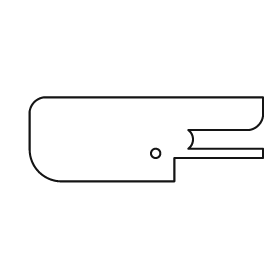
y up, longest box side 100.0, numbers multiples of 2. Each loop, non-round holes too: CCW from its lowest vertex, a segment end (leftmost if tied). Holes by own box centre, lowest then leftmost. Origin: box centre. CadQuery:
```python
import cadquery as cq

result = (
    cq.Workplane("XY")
    .moveTo(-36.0, -18.0)
    .lineTo(12.0, -18.0)
    .lineTo(12.0, -8.0)
    .lineTo(50.0, -8.0)
    .lineTo(50.0, -4.0)
    .lineTo(18.0, -4.0)
    .threePointArc((20.0, 0.0), (18.0, 4.0))
    .lineTo(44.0, 4.0)
    .threePointArc((48.0, 6.0), (50.0, 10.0))
    .lineTo(50.0, 18.0)
    .lineTo(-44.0, 18.0)
    .threePointArc((-48.0, 16.0), (-50.0, 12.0))
    .lineTo(-50.0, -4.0)
    .threePointArc((-46.0, -14.0), (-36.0, -18.0))
    .close()
    .moveTo(4.0, -6.0)
    .circle(2.0)
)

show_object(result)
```